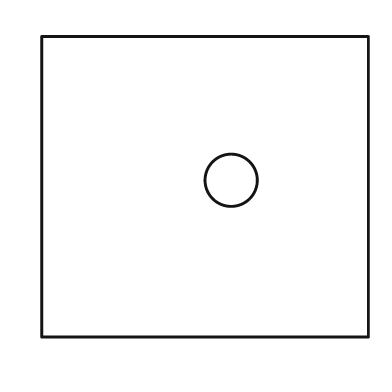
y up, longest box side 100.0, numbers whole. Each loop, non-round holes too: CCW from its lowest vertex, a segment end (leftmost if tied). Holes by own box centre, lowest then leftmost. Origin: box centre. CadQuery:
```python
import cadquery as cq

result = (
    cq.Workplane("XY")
    .moveTo(-50.0, -46.0)
    .lineTo(50.0, -46.0)
    .lineTo(50.0, 46.0)
    .lineTo(-50.0, 46.0)
    .close()
    .moveTo(8.0, 2.0)
    .circle(8.0)
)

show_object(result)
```